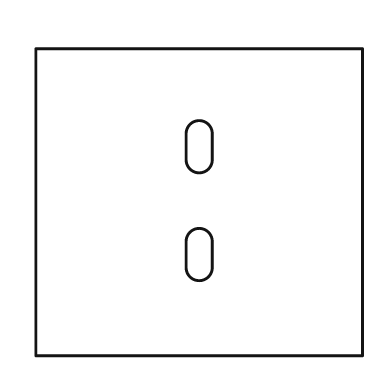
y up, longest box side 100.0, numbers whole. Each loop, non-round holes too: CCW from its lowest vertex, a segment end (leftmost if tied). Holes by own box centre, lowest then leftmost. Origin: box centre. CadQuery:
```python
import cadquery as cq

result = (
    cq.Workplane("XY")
    .moveTo(-50.0, -47.0)
    .lineTo(50.0, -47.0)
    .lineTo(50.0, 47.0)
    .lineTo(-50.0, 47.0)
    .close()
    .moveTo(-4.0, -20.0)
    .threePointArc((0.0, -24.0), (4.0, -20.0))
    .lineTo(4.0, -12.0)
    .threePointArc((0.0, -8.0), (-4.0, -12.0))
    .close()
    .moveTo(-4.0, 13.0)
    .threePointArc((0.0, 9.0), (4.0, 13.0))
    .lineTo(4.0, 21.0)
    .threePointArc((0.0, 25.0), (-4.0, 21.0))
    .close()
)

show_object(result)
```